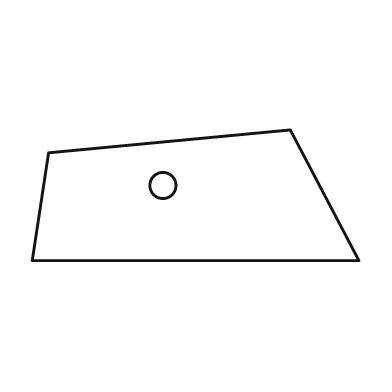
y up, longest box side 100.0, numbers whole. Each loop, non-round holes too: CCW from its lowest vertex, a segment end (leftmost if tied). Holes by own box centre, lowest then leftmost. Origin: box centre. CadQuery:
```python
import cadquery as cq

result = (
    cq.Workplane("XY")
    .moveTo(-50.0, -20.0)
    .lineTo(50.0, -20.0)
    .lineTo(29.0, 20.0)
    .lineTo(-45.0, 13.0)
    .close()
    .moveTo(-10.0, 3.0)
    .circle(4.0)
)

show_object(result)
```